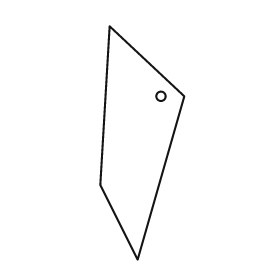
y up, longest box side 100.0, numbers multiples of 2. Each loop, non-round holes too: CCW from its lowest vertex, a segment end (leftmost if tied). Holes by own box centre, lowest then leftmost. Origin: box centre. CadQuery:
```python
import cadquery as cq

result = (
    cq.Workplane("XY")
    .moveTo(-2.0, -50.0)
    .lineTo(18.0, 20.0)
    .lineTo(-14.0, 50.0)
    .lineTo(-18.0, -18.0)
    .close()
    .moveTo(8.0, 20.0)
    .circle(2.0)
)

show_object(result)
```